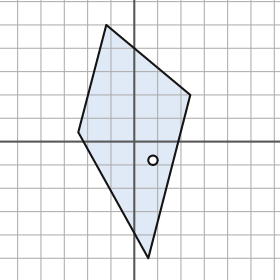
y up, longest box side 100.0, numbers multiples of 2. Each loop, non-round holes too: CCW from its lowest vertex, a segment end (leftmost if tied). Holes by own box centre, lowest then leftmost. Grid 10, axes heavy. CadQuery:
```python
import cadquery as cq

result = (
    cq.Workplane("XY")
    .moveTo(6.0, -50.0)
    .lineTo(24.0, 20.0)
    .lineTo(-12.0, 50.0)
    .lineTo(-24.0, 4.0)
    .close()
    .moveTo(8.0, -8.0)
    .circle(2.0)
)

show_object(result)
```